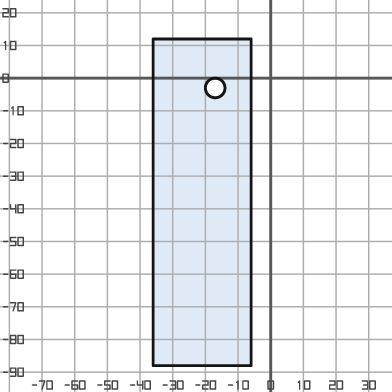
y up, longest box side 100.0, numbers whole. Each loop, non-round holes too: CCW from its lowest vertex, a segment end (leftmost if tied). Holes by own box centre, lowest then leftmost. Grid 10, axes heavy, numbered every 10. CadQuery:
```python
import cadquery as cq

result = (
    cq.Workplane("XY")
    .moveTo(-36.0, -88.0)
    .lineTo(-6.0, -88.0)
    .lineTo(-6.0, 12.0)
    .lineTo(-36.0, 12.0)
    .close()
    .moveTo(-17.0, -3.0)
    .circle(3.0)
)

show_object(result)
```